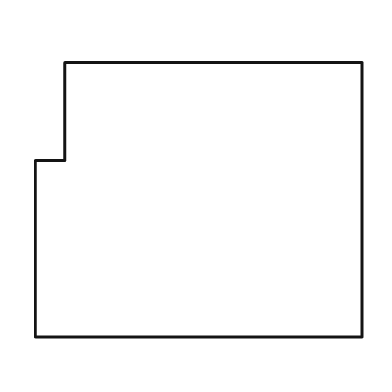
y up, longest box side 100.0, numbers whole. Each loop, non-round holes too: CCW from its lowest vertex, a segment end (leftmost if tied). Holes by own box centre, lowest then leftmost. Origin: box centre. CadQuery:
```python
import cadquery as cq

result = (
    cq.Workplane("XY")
    .moveTo(-50.0, -42.0)
    .lineTo(50.0, -42.0)
    .lineTo(50.0, 42.0)
    .lineTo(-41.0, 42.0)
    .lineTo(-41.0, 12.0)
    .lineTo(-50.0, 12.0)
    .close()
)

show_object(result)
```